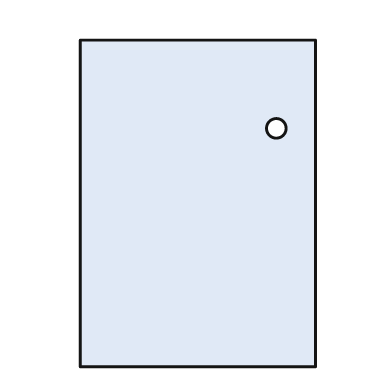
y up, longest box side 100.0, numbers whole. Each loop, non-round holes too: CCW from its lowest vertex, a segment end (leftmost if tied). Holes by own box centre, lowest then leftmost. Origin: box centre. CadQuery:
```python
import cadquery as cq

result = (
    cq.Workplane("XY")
    .moveTo(-36.0, -50.0)
    .lineTo(36.0, -50.0)
    .lineTo(36.0, 50.0)
    .lineTo(-36.0, 50.0)
    .close()
    .moveTo(24.0, 23.0)
    .circle(3.0)
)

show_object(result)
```